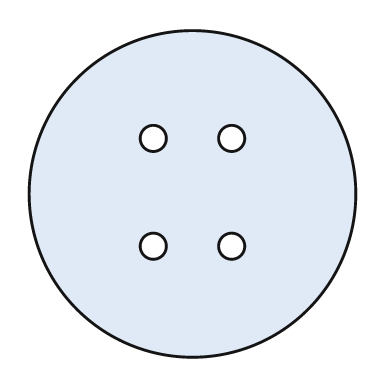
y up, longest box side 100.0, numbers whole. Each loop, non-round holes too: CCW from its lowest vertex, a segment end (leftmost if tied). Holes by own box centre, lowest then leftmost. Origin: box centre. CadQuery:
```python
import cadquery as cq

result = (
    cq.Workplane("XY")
    .moveTo(0.0, 0.0)
    .circle(50.0)
    .moveTo(-12.0, -16.0)
    .circle(4.0)
    .moveTo(12.0, -16.0)
    .circle(4.0)
    .moveTo(-12.0, 17.0)
    .circle(4.0)
    .moveTo(12.0, 17.0)
    .circle(4.0)
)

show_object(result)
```